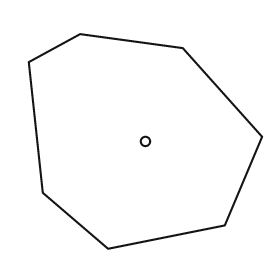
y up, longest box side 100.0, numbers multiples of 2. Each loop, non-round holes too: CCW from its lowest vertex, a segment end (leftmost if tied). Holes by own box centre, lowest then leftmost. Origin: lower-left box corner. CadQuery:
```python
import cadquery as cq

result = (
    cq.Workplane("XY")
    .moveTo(34.0, 0.0)
    .lineTo(84.0, 10.0)
    .lineTo(100.0, 48.0)
    .lineTo(66.0, 86.0)
    .lineTo(22.0, 92.0)
    .lineTo(0.0, 80.0)
    .lineTo(6.0, 24.0)
    .close()
    .moveTo(50.0, 46.0)
    .circle(2.0)
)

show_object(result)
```